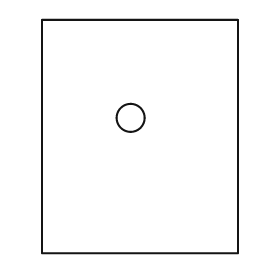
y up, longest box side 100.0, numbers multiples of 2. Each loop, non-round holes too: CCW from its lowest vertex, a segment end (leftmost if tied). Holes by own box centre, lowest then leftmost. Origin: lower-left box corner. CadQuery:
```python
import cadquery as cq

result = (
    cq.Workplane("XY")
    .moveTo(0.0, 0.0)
    .lineTo(84.0, 0.0)
    .lineTo(84.0, 100.0)
    .lineTo(0.0, 100.0)
    .close()
    .moveTo(38.0, 58.0)
    .circle(6.0)
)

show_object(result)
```